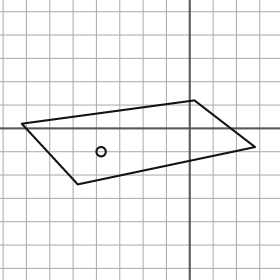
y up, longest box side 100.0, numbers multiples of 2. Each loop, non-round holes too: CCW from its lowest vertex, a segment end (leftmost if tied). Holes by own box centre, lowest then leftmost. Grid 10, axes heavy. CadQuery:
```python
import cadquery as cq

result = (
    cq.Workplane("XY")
    .moveTo(-48.0, -24.0)
    .lineTo(28.0, -8.0)
    .lineTo(2.0, 12.0)
    .lineTo(-72.0, 2.0)
    .close()
    .moveTo(-38.0, -10.0)
    .circle(2.0)
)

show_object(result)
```